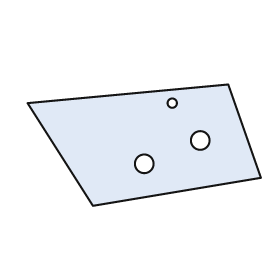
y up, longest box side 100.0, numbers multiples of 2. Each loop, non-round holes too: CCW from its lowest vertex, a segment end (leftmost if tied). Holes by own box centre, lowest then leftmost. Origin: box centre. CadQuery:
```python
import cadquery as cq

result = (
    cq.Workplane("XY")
    .moveTo(-22.0, -26.0)
    .lineTo(50.0, -14.0)
    .lineTo(36.0, 26.0)
    .lineTo(-50.0, 18.0)
    .close()
    .moveTo(0.0, -8.0)
    .circle(4.0)
    .moveTo(24.0, 2.0)
    .circle(4.0)
    .moveTo(12.0, 18.0)
    .circle(2.0)
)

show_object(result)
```